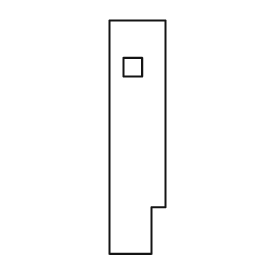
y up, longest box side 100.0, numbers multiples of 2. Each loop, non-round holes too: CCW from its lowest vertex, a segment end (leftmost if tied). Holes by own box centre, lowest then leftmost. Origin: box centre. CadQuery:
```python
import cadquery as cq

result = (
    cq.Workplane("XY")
    .moveTo(-12.0, -50.0)
    .lineTo(6.0, -50.0)
    .lineTo(6.0, -30.0)
    .lineTo(12.0, -30.0)
    .lineTo(12.0, 50.0)
    .lineTo(-12.0, 50.0)
    .close()
    .moveTo(-6.0, 26.0)
    .lineTo(2.0, 26.0)
    .lineTo(2.0, 34.0)
    .lineTo(-6.0, 34.0)
    .close()
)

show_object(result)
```